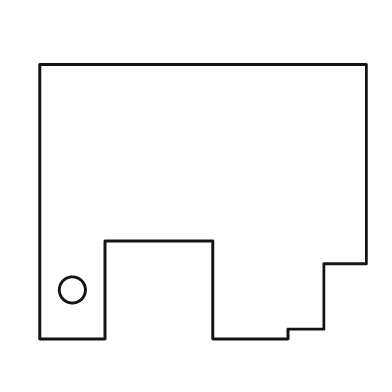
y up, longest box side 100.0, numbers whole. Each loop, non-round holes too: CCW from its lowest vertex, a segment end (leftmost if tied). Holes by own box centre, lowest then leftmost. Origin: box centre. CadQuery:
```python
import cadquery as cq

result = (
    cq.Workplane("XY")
    .moveTo(-50.0, -42.0)
    .lineTo(-30.0, -42.0)
    .lineTo(-30.0, -12.0)
    .lineTo(3.0, -12.0)
    .lineTo(3.0, -42.0)
    .lineTo(26.0, -42.0)
    .lineTo(26.0, -39.0)
    .lineTo(37.0, -39.0)
    .lineTo(37.0, -19.0)
    .lineTo(50.0, -19.0)
    .lineTo(50.0, 42.0)
    .lineTo(-50.0, 42.0)
    .close()
    .moveTo(-40.0, -27.0)
    .circle(4.0)
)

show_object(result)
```